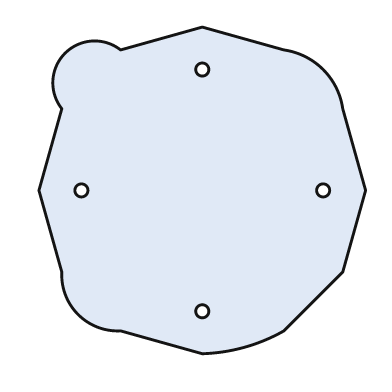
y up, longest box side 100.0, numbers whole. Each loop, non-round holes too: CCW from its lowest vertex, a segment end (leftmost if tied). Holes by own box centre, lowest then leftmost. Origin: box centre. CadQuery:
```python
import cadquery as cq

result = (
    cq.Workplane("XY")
    .moveTo(0.0, -50.0)
    .threePointArc((13.0, -48.0), (25.0, -43.0))
    .lineTo(43.0, -25.0)
    .lineTo(50.0, 0.0)
    .lineTo(43.0, 25.0)
    .threePointArc((37.0, 37.0), (25.0, 43.0))
    .lineTo(0.0, 50.0)
    .lineTo(-25.0, 43.0)
    .threePointArc((-42.0, 42.0), (-43.0, 25.0))
    .lineTo(-50.0, 0.0)
    .lineTo(-43.0, -25.0)
    .threePointArc((-38.0, -38.0), (-25.0, -43.0))
    .close()
    .moveTo(0.0, -37.0)
    .circle(2.0)
    .moveTo(-37.0, 0.0)
    .circle(2.0)
    .moveTo(37.0, 0.0)
    .circle(2.0)
    .moveTo(0.0, 37.0)
    .circle(2.0)
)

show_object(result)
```